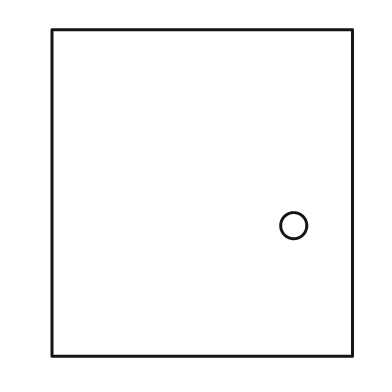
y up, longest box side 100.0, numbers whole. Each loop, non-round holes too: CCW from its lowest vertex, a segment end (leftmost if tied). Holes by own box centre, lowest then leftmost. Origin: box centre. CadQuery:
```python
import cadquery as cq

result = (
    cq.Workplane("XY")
    .moveTo(-46.0, -50.0)
    .lineTo(46.0, -50.0)
    .lineTo(46.0, 50.0)
    .lineTo(-46.0, 50.0)
    .close()
    .moveTo(28.0, -10.0)
    .circle(4.0)
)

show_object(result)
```